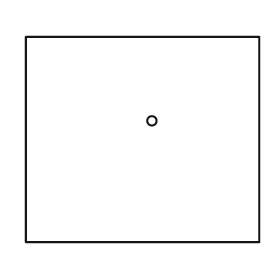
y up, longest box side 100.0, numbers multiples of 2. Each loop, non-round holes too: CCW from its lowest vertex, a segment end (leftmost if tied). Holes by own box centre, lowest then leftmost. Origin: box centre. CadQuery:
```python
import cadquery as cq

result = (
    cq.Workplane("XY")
    .moveTo(-50.0, -44.0)
    .lineTo(50.0, -44.0)
    .lineTo(50.0, 44.0)
    .lineTo(-50.0, 44.0)
    .close()
    .moveTo(4.0, 8.0)
    .circle(2.0)
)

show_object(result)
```